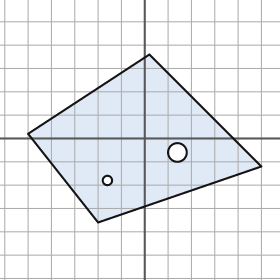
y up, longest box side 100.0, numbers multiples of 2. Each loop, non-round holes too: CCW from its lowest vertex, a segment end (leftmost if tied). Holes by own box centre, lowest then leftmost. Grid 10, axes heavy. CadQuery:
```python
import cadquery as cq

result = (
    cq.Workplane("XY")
    .moveTo(-20.0, -36.0)
    .lineTo(50.0, -12.0)
    .lineTo(2.0, 36.0)
    .lineTo(-50.0, 2.0)
    .close()
    .moveTo(-16.0, -18.0)
    .circle(2.0)
    .moveTo(14.0, -6.0)
    .circle(4.0)
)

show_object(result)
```